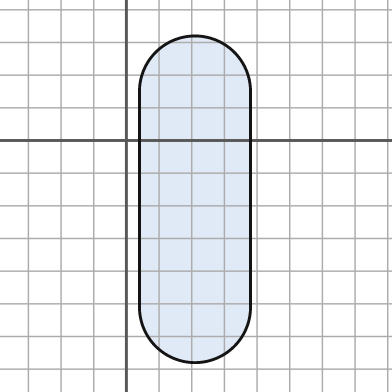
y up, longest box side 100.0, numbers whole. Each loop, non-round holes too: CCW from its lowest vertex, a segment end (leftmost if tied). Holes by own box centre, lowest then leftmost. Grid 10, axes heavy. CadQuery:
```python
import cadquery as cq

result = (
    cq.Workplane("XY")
    .moveTo(4.0, -51.0)
    .threePointArc((21.0, -68.0), (38.0, -51.0))
    .lineTo(38.0, 15.0)
    .threePointArc((21.0, 32.0), (4.0, 15.0))
    .close()
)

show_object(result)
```